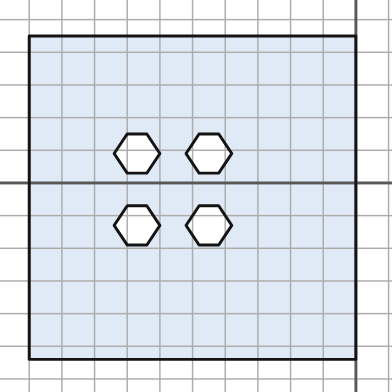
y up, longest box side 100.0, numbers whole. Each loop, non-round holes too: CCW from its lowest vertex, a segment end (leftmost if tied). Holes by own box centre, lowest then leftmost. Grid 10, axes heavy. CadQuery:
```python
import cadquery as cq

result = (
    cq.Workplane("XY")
    .moveTo(-100.0, -54.0)
    .lineTo(0.0, -54.0)
    .lineTo(0.0, 45.0)
    .lineTo(-100.0, 45.0)
    .close()
    .moveTo(-70.0, -19.0)
    .lineTo(-64.0, -19.0)
    .lineTo(-60.0, -13.0)
    .lineTo(-64.0, -7.0)
    .lineTo(-70.0, -7.0)
    .lineTo(-74.0, -13.0)
    .close()
    .moveTo(-48.0, -19.0)
    .lineTo(-42.0, -19.0)
    .lineTo(-38.0, -13.0)
    .lineTo(-42.0, -7.0)
    .lineTo(-48.0, -7.0)
    .lineTo(-52.0, -13.0)
    .close()
    .moveTo(-70.0, 3.0)
    .lineTo(-64.0, 3.0)
    .lineTo(-60.0, 9.0)
    .lineTo(-64.0, 15.0)
    .lineTo(-70.0, 15.0)
    .lineTo(-74.0, 9.0)
    .close()
    .moveTo(-48.0, 3.0)
    .lineTo(-42.0, 3.0)
    .lineTo(-38.0, 9.0)
    .lineTo(-42.0, 15.0)
    .lineTo(-48.0, 15.0)
    .lineTo(-52.0, 9.0)
    .close()
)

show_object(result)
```